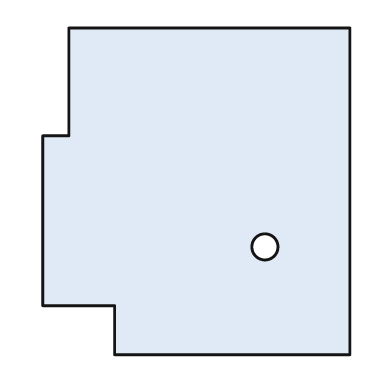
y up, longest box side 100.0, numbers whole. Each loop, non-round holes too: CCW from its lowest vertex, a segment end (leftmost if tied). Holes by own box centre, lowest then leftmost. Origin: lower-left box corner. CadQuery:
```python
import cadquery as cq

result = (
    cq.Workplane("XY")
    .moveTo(22.0, 0.0)
    .lineTo(94.0, 0.0)
    .lineTo(94.0, 100.0)
    .lineTo(8.0, 100.0)
    .lineTo(8.0, 67.0)
    .lineTo(0.0, 67.0)
    .lineTo(0.0, 15.0)
    .lineTo(22.0, 15.0)
    .close()
    .moveTo(68.0, 33.0)
    .circle(4.0)
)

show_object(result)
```